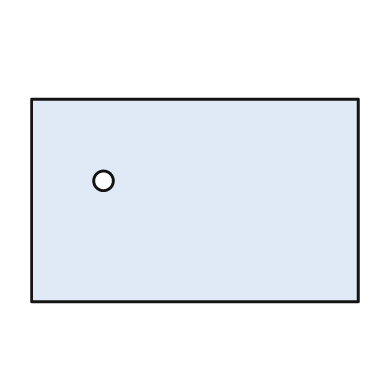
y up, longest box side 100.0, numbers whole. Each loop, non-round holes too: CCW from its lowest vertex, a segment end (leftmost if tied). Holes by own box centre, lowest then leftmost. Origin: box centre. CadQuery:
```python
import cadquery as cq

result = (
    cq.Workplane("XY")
    .moveTo(-50.0, -31.0)
    .lineTo(50.0, -31.0)
    .lineTo(50.0, 31.0)
    .lineTo(-50.0, 31.0)
    .close()
    .moveTo(-28.0, 6.0)
    .circle(3.0)
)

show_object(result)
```